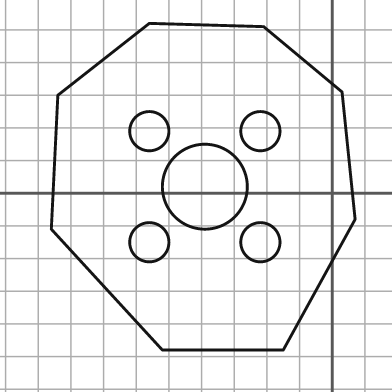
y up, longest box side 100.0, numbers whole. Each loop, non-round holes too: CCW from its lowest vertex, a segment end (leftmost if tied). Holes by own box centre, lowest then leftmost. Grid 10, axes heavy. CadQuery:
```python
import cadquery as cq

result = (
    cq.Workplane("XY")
    .moveTo(-52.0, -48.0)
    .lineTo(-15.0, -48.0)
    .lineTo(7.0, -8.0)
    .lineTo(3.0, 31.0)
    .lineTo(-21.0, 51.0)
    .lineTo(-56.0, 52.0)
    .lineTo(-84.0, 30.0)
    .lineTo(-86.0, -11.0)
    .close()
    .moveTo(-56.0, -15.0)
    .circle(6.0)
    .moveTo(-22.0, -15.0)
    .circle(6.0)
    .moveTo(-39.0, 2.0)
    .circle(13.0)
    .moveTo(-56.0, 19.0)
    .circle(6.0)
    .moveTo(-22.0, 19.0)
    .circle(6.0)
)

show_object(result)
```